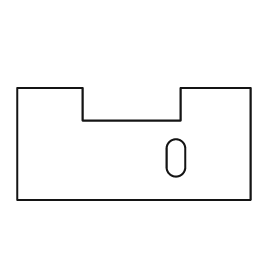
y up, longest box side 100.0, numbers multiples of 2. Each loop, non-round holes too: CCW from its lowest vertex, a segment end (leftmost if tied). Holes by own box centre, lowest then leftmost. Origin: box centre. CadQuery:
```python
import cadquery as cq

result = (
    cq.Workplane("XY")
    .moveTo(-50.0, -24.0)
    .lineTo(50.0, -24.0)
    .lineTo(50.0, 24.0)
    .lineTo(20.0, 24.0)
    .lineTo(20.0, 10.0)
    .lineTo(-22.0, 10.0)
    .lineTo(-22.0, 24.0)
    .lineTo(-50.0, 24.0)
    .close()
    .moveTo(14.0, -10.0)
    .threePointArc((18.0, -14.0), (22.0, -10.0))
    .lineTo(22.0, -2.0)
    .threePointArc((18.0, 2.0), (14.0, -2.0))
    .close()
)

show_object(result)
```